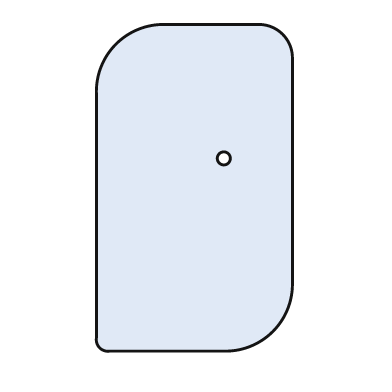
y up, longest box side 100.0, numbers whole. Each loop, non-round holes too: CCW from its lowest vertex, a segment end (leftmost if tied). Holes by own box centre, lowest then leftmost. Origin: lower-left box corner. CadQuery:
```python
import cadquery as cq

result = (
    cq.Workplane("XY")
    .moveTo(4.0, 0.0)
    .lineTo(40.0, 0.0)
    .threePointArc((54.0, 6.0), (60.0, 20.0))
    .lineTo(60.0, 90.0)
    .threePointArc((57.0, 97.0), (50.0, 100.0))
    .lineTo(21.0, 100.0)
    .threePointArc((6.0, 94.0), (0.0, 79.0))
    .lineTo(0.0, 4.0)
    .threePointArc((1.0, 1.0), (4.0, 0.0))
    .close()
    .moveTo(39.0, 59.0)
    .circle(2.0)
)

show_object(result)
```